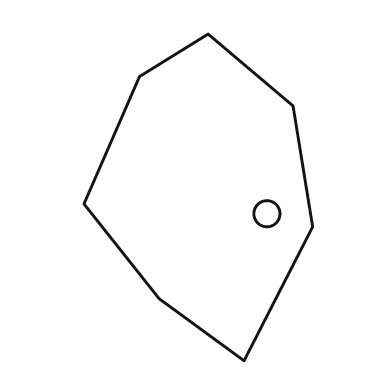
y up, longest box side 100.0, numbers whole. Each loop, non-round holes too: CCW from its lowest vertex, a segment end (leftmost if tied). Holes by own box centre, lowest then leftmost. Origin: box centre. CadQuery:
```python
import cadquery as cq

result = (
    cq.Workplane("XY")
    .moveTo(14.0, -50.0)
    .lineTo(35.0, -9.0)
    .lineTo(29.0, 28.0)
    .lineTo(3.0, 50.0)
    .lineTo(-18.0, 37.0)
    .lineTo(-35.0, -2.0)
    .lineTo(-12.0, -31.0)
    .close()
    .moveTo(21.0, -5.0)
    .circle(4.0)
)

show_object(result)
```